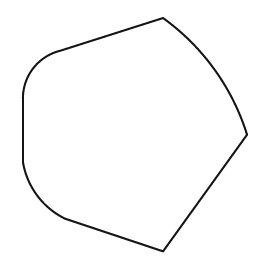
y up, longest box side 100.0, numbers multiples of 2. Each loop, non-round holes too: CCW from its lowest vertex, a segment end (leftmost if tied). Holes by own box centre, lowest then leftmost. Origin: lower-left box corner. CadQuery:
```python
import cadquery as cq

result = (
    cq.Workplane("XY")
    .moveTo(60.0, 0.0)
    .lineTo(96.0, 50.0)
    .threePointArc((82.0, 78.0), (60.0, 100.0))
    .lineTo(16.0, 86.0)
    .threePointArc((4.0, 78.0), (0.0, 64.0))
    .lineTo(0.0, 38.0)
    .threePointArc((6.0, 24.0), (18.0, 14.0))
    .close()
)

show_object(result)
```